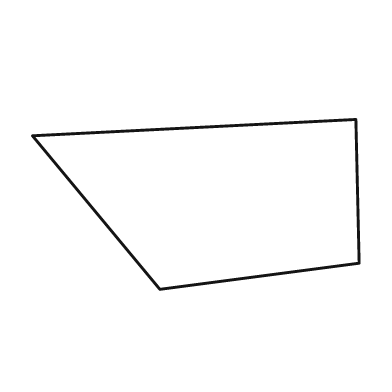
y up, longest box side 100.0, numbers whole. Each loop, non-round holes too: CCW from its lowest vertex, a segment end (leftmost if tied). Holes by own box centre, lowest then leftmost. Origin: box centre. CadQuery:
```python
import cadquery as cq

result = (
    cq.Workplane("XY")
    .moveTo(-11.0, -26.0)
    .lineTo(50.0, -18.0)
    .lineTo(49.0, 26.0)
    .lineTo(-50.0, 21.0)
    .close()
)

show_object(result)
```